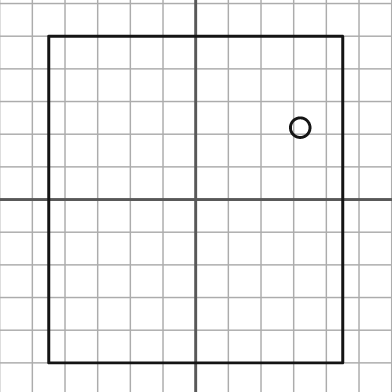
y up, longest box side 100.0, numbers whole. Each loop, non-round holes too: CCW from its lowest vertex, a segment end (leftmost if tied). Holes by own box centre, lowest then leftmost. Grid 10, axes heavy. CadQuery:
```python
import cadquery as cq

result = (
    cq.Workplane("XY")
    .moveTo(-45.0, -50.0)
    .lineTo(45.0, -50.0)
    .lineTo(45.0, 50.0)
    .lineTo(-45.0, 50.0)
    .close()
    .moveTo(32.0, 22.0)
    .circle(3.0)
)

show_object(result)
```